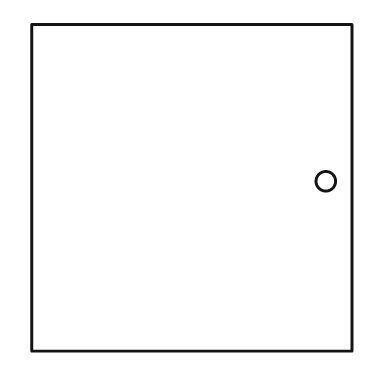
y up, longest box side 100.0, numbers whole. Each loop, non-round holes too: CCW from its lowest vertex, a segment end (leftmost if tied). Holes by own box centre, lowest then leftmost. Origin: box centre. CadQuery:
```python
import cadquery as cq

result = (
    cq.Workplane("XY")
    .moveTo(-49.0, -50.0)
    .lineTo(49.0, -50.0)
    .lineTo(49.0, 50.0)
    .lineTo(-49.0, 50.0)
    .close()
    .moveTo(41.0, 2.0)
    .circle(3.0)
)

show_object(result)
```